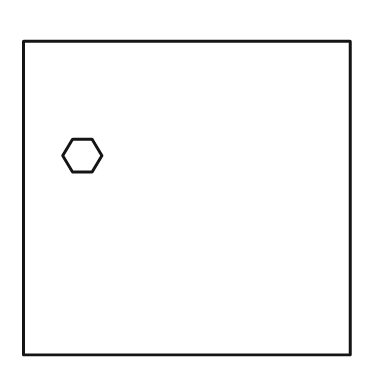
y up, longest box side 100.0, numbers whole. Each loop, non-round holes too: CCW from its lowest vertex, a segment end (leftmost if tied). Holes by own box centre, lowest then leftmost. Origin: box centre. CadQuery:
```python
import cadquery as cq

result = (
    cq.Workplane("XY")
    .moveTo(-50.0, -48.0)
    .lineTo(50.0, -48.0)
    .lineTo(50.0, 48.0)
    .lineTo(-50.0, 48.0)
    .close()
    .moveTo(-35.0, 8.0)
    .lineTo(-29.0, 8.0)
    .lineTo(-26.0, 13.0)
    .lineTo(-29.0, 18.0)
    .lineTo(-35.0, 18.0)
    .lineTo(-38.0, 13.0)
    .close()
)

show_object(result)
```